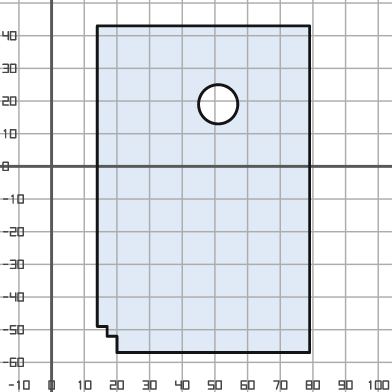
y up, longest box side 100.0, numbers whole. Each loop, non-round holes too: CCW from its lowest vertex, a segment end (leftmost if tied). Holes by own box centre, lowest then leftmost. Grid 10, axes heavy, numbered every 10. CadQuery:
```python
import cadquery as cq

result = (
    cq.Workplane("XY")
    .moveTo(20.0, -57.0)
    .lineTo(79.0, -57.0)
    .lineTo(79.0, 43.0)
    .lineTo(14.0, 43.0)
    .lineTo(14.0, -49.0)
    .lineTo(17.0, -49.0)
    .lineTo(17.0, -52.0)
    .lineTo(20.0, -52.0)
    .close()
    .moveTo(51.0, 19.0)
    .circle(6.0)
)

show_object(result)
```